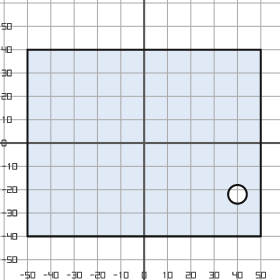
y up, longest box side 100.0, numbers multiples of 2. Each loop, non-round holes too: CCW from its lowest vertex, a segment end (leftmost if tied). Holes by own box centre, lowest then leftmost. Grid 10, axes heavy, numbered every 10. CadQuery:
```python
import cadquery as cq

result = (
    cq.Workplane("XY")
    .moveTo(-50.0, -40.0)
    .lineTo(50.0, -40.0)
    .lineTo(50.0, 40.0)
    .lineTo(-50.0, 40.0)
    .close()
    .moveTo(40.0, -22.0)
    .circle(4.0)
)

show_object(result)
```